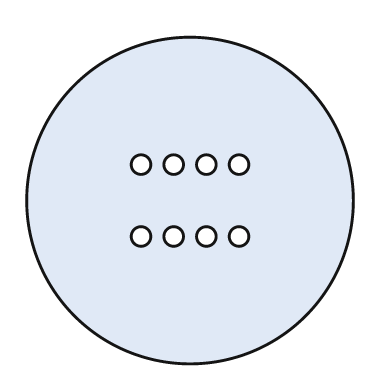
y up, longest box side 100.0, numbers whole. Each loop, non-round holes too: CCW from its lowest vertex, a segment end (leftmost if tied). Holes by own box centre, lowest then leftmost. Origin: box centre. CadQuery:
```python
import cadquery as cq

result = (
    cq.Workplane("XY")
    .moveTo(0.0, 0.0)
    .circle(50.0)
    .moveTo(-15.0, -11.0)
    .circle(3.0)
    .moveTo(-5.0, -11.0)
    .circle(3.0)
    .moveTo(5.0, -11.0)
    .circle(3.0)
    .moveTo(15.0, -11.0)
    .circle(3.0)
    .moveTo(-15.0, 11.0)
    .circle(3.0)
    .moveTo(-5.0, 11.0)
    .circle(3.0)
    .moveTo(5.0, 11.0)
    .circle(3.0)
    .moveTo(15.0, 11.0)
    .circle(3.0)
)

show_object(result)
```